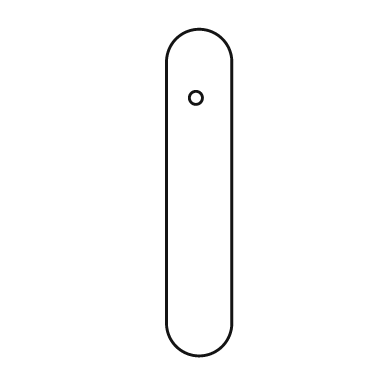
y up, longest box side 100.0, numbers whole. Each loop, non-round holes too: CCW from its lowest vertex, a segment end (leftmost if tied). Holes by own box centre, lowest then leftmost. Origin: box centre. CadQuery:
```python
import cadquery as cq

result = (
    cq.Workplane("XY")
    .moveTo(-10.0, -40.0)
    .threePointArc((0.0, -50.0), (10.0, -40.0))
    .lineTo(10.0, 40.0)
    .threePointArc((0.0, 50.0), (-10.0, 40.0))
    .close()
    .moveTo(-1.0, 29.0)
    .circle(2.0)
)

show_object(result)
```